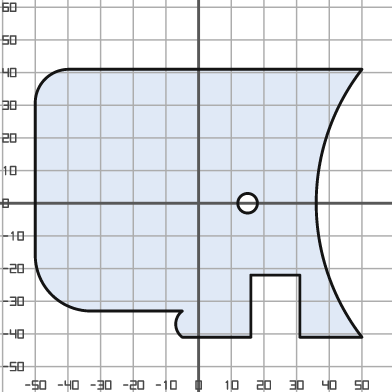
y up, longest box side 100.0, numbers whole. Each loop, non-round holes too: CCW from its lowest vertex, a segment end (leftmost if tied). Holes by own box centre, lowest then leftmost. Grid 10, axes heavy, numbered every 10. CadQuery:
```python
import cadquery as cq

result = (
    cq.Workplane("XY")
    .moveTo(-5.0, -41.0)
    .lineTo(16.0, -41.0)
    .lineTo(16.0, -22.0)
    .lineTo(31.0, -22.0)
    .lineTo(31.0, -41.0)
    .lineTo(50.0, -41.0)
    .threePointArc((36.0, 0.0), (50.0, 41.0))
    .lineTo(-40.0, 41.0)
    .threePointArc((-47.0, 38.0), (-50.0, 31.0))
    .lineTo(-50.0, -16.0)
    .threePointArc((-45.0, -28.0), (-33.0, -33.0))
    .lineTo(-5.0, -33.0)
    .threePointArc((-7.0, -37.0), (-5.0, -41.0))
    .close()
    .moveTo(15.0, 0.0)
    .circle(3.0)
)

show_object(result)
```